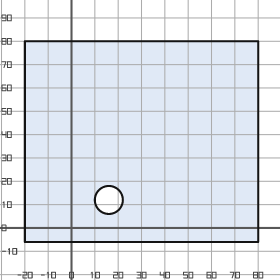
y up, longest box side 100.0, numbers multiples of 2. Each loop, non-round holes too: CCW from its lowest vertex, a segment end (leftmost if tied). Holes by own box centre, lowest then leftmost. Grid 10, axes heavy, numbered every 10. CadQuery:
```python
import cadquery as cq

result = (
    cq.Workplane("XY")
    .moveTo(-20.0, -6.0)
    .lineTo(80.0, -6.0)
    .lineTo(80.0, 80.0)
    .lineTo(-20.0, 80.0)
    .close()
    .moveTo(16.0, 12.0)
    .circle(6.0)
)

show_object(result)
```